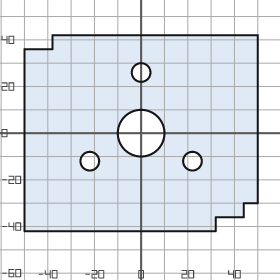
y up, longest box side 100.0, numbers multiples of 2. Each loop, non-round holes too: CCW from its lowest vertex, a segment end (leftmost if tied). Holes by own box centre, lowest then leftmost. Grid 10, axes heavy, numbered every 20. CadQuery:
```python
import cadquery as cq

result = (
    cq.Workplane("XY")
    .moveTo(-50.0, -42.0)
    .lineTo(32.0, -42.0)
    .lineTo(32.0, -36.0)
    .lineTo(44.0, -36.0)
    .lineTo(44.0, -30.0)
    .lineTo(50.0, -30.0)
    .lineTo(50.0, 42.0)
    .lineTo(-38.0, 42.0)
    .lineTo(-38.0, 36.0)
    .lineTo(-50.0, 36.0)
    .close()
    .moveTo(-22.0, -12.0)
    .circle(4.0)
    .moveTo(22.0, -12.0)
    .circle(4.0)
    .moveTo(0.0, 0.0)
    .circle(10.0)
    .moveTo(0.0, 26.0)
    .circle(4.0)
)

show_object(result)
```